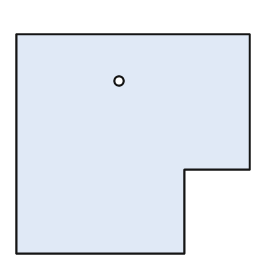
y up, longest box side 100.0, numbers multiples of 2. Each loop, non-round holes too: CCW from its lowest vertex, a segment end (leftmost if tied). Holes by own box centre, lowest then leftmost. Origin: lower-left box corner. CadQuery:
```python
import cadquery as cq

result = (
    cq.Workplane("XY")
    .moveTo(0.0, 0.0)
    .lineTo(72.0, 0.0)
    .lineTo(72.0, 36.0)
    .lineTo(100.0, 36.0)
    .lineTo(100.0, 94.0)
    .lineTo(0.0, 94.0)
    .close()
    .moveTo(44.0, 74.0)
    .circle(2.0)
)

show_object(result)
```